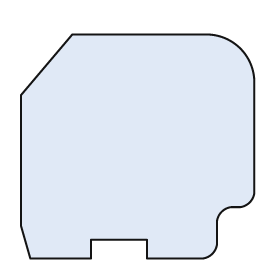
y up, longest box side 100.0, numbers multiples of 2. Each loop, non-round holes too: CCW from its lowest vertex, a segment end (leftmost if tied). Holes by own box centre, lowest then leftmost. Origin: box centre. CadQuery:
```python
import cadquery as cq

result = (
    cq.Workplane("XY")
    .moveTo(-46.0, -48.0)
    .lineTo(-20.0, -48.0)
    .lineTo(-20.0, -40.0)
    .lineTo(4.0, -40.0)
    .lineTo(4.0, -48.0)
    .lineTo(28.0, -48.0)
    .threePointArc((32.0, -46.0), (34.0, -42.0))
    .lineTo(34.0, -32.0)
    .threePointArc((36.0, -28.0), (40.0, -26.0))
    .lineTo(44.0, -26.0)
    .threePointArc((48.0, -24.0), (50.0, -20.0))
    .lineTo(50.0, 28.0)
    .threePointArc((44.0, 42.0), (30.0, 48.0))
    .lineTo(-28.0, 48.0)
    .lineTo(-50.0, 22.0)
    .lineTo(-50.0, -34.0)
    .close()
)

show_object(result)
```